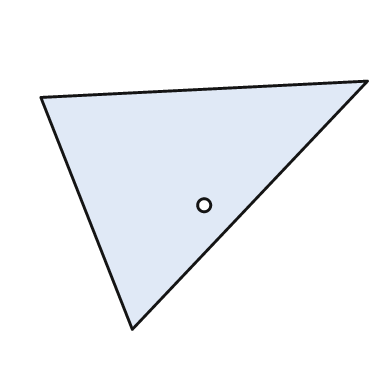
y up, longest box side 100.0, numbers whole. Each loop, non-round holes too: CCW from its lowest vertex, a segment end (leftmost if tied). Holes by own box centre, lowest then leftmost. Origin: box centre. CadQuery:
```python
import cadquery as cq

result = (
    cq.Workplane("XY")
    .moveTo(-22.0, -38.0)
    .lineTo(50.0, 38.0)
    .lineTo(-50.0, 33.0)
    .close()
    .moveTo(0.0, 0.0)
    .circle(2.0)
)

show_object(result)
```